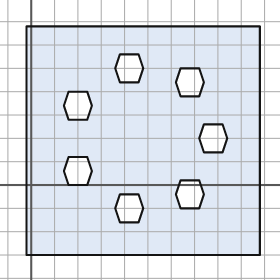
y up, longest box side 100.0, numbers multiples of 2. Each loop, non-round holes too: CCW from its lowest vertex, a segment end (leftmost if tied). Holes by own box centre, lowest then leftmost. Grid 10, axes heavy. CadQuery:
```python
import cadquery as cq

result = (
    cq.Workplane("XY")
    .moveTo(-2.0, -30.0)
    .lineTo(98.0, -30.0)
    .lineTo(98.0, 68.0)
    .lineTo(-2.0, 68.0)
    .close()
    .moveTo(38.0, -16.0)
    .lineTo(46.0, -16.0)
    .lineTo(48.0, -10.0)
    .lineTo(46.0, -4.0)
    .lineTo(38.0, -4.0)
    .lineTo(36.0, -10.0)
    .close()
    .moveTo(64.0, -10.0)
    .lineTo(72.0, -10.0)
    .lineTo(74.0, -4.0)
    .lineTo(72.0, 2.0)
    .lineTo(64.0, 2.0)
    .lineTo(62.0, -4.0)
    .close()
    .moveTo(16.0, 0.0)
    .lineTo(24.0, 0.0)
    .lineTo(26.0, 6.0)
    .lineTo(24.0, 12.0)
    .lineTo(16.0, 12.0)
    .lineTo(14.0, 6.0)
    .close()
    .moveTo(74.0, 14.0)
    .lineTo(82.0, 14.0)
    .lineTo(84.0, 20.0)
    .lineTo(82.0, 26.0)
    .lineTo(74.0, 26.0)
    .lineTo(72.0, 20.0)
    .close()
    .moveTo(16.0, 28.0)
    .lineTo(24.0, 28.0)
    .lineTo(26.0, 34.0)
    .lineTo(24.0, 40.0)
    .lineTo(16.0, 40.0)
    .lineTo(14.0, 34.0)
    .close()
    .moveTo(64.0, 38.0)
    .lineTo(72.0, 38.0)
    .lineTo(74.0, 44.0)
    .lineTo(72.0, 50.0)
    .lineTo(64.0, 50.0)
    .lineTo(62.0, 44.0)
    .close()
    .moveTo(38.0, 44.0)
    .lineTo(46.0, 44.0)
    .lineTo(48.0, 50.0)
    .lineTo(46.0, 56.0)
    .lineTo(38.0, 56.0)
    .lineTo(36.0, 50.0)
    .close()
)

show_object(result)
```